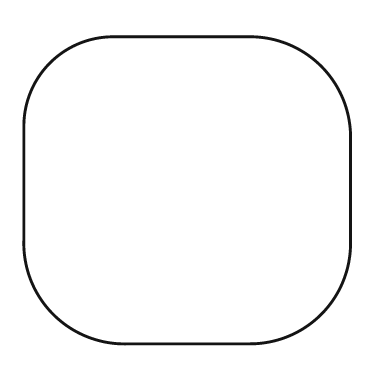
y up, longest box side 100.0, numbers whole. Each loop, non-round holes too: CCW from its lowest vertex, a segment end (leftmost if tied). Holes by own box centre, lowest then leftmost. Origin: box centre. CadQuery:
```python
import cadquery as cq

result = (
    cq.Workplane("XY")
    .moveTo(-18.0, -47.0)
    .lineTo(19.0, -47.0)
    .threePointArc((41.0, -38.0), (50.0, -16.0))
    .lineTo(50.0, 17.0)
    .threePointArc((41.0, 38.0), (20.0, 47.0))
    .lineTo(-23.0, 47.0)
    .threePointArc((-42.0, 39.0), (-50.0, 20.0))
    .lineTo(-50.0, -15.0)
    .threePointArc((-41.0, -38.0), (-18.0, -47.0))
    .close()
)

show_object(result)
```